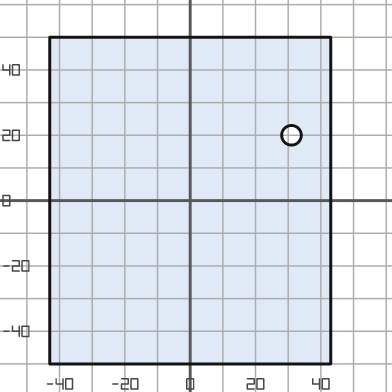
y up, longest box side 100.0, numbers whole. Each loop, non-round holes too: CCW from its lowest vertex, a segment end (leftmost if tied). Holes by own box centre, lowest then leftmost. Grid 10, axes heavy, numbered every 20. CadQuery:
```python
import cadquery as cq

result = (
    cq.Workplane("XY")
    .moveTo(-43.0, -50.0)
    .lineTo(43.0, -50.0)
    .lineTo(43.0, 50.0)
    .lineTo(-43.0, 50.0)
    .close()
    .moveTo(31.0, 20.0)
    .circle(3.0)
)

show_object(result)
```